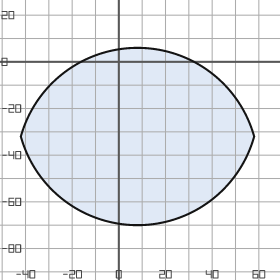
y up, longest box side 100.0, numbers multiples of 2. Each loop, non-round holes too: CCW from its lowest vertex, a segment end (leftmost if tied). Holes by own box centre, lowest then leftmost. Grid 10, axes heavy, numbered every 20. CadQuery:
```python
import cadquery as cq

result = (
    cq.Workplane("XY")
    .moveTo(-42.0, -32.0)
    .threePointArc((8.0, -70.0), (58.0, -32.0))
    .threePointArc((8.0, 6.0), (-42.0, -32.0))
    .close()
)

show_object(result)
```